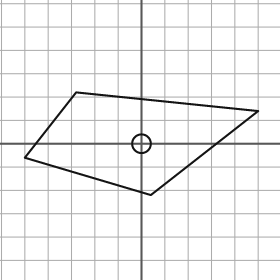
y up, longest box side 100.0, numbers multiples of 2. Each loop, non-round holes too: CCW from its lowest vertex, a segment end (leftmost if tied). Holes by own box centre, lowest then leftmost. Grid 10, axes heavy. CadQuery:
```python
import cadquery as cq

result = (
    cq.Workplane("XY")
    .moveTo(4.0, -22.0)
    .lineTo(50.0, 14.0)
    .lineTo(-28.0, 22.0)
    .lineTo(-50.0, -6.0)
    .close()
    .moveTo(0.0, 0.0)
    .circle(4.0)
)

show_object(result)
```